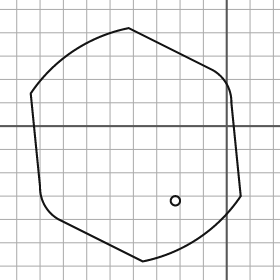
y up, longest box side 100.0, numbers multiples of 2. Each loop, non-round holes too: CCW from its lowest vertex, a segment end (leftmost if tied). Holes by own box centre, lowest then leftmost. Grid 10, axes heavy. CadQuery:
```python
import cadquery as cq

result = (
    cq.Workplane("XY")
    .moveTo(-36.0, -58.0)
    .threePointArc((-12.0, -48.0), (6.0, -30.0))
    .lineTo(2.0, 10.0)
    .threePointArc((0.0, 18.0), (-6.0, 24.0))
    .lineTo(-42.0, 42.0)
    .threePointArc((-66.0, 32.0), (-84.0, 14.0))
    .lineTo(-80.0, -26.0)
    .threePointArc((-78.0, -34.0), (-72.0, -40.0))
    .close()
    .moveTo(-22.0, -32.0)
    .circle(2.0)
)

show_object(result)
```